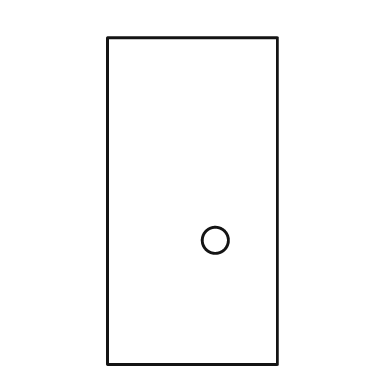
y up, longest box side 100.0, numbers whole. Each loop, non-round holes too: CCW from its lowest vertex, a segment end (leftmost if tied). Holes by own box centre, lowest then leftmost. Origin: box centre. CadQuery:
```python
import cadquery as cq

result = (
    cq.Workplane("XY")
    .moveTo(-26.0, -50.0)
    .lineTo(26.0, -50.0)
    .lineTo(26.0, 50.0)
    .lineTo(-26.0, 50.0)
    .close()
    .moveTo(7.0, -12.0)
    .circle(4.0)
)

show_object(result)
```